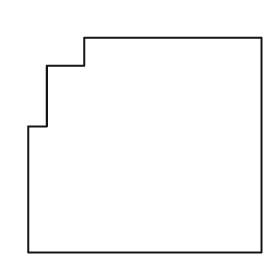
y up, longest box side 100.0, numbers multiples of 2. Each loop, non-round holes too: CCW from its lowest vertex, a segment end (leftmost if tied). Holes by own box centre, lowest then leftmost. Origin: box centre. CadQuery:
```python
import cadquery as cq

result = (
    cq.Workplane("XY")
    .moveTo(-50.0, -46.0)
    .lineTo(50.0, -46.0)
    .lineTo(50.0, 46.0)
    .lineTo(-26.0, 46.0)
    .lineTo(-26.0, 34.0)
    .lineTo(-42.0, 34.0)
    .lineTo(-42.0, 8.0)
    .lineTo(-50.0, 8.0)
    .close()
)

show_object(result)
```